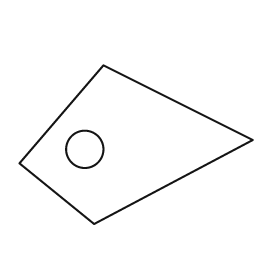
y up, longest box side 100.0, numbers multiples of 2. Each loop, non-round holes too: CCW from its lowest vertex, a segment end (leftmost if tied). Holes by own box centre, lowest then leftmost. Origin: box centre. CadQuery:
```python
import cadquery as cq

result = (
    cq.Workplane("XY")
    .moveTo(-18.0, -34.0)
    .lineTo(50.0, 2.0)
    .lineTo(-14.0, 34.0)
    .lineTo(-50.0, -8.0)
    .close()
    .moveTo(-22.0, -2.0)
    .circle(8.0)
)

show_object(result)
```